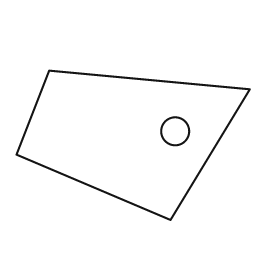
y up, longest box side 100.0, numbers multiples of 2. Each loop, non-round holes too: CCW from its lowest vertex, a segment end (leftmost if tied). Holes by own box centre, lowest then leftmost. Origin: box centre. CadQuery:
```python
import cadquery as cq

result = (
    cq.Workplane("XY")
    .moveTo(16.0, -32.0)
    .lineTo(50.0, 24.0)
    .lineTo(-36.0, 32.0)
    .lineTo(-50.0, -4.0)
    .close()
    .moveTo(18.0, 6.0)
    .circle(6.0)
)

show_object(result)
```